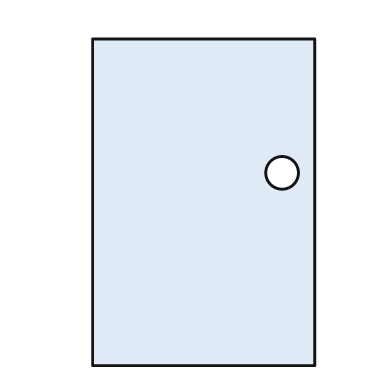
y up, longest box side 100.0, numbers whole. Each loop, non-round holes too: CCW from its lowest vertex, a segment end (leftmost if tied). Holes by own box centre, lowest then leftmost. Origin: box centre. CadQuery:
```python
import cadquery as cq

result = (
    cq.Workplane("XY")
    .moveTo(-34.0, -50.0)
    .lineTo(34.0, -50.0)
    .lineTo(34.0, 50.0)
    .lineTo(-34.0, 50.0)
    .close()
    .moveTo(24.0, 9.0)
    .circle(5.0)
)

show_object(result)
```